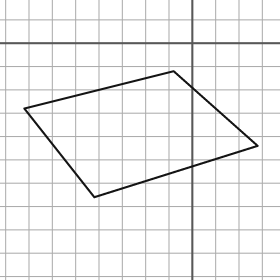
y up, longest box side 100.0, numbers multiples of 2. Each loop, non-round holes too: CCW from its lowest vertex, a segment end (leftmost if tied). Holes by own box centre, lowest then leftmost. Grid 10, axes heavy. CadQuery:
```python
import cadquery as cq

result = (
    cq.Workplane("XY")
    .moveTo(-42.0, -66.0)
    .lineTo(28.0, -44.0)
    .lineTo(-8.0, -12.0)
    .lineTo(-72.0, -28.0)
    .close()
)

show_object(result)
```